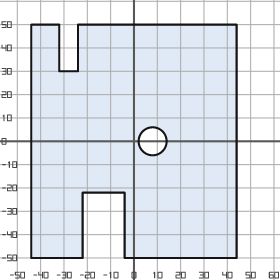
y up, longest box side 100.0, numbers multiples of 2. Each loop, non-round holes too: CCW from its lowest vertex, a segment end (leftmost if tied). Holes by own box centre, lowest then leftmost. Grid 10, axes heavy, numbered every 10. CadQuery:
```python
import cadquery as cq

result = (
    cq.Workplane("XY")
    .moveTo(-44.0, -50.0)
    .lineTo(-22.0, -50.0)
    .lineTo(-22.0, -22.0)
    .lineTo(-4.0, -22.0)
    .lineTo(-4.0, -50.0)
    .lineTo(44.0, -50.0)
    .lineTo(44.0, 50.0)
    .lineTo(-24.0, 50.0)
    .lineTo(-24.0, 30.0)
    .lineTo(-32.0, 30.0)
    .lineTo(-32.0, 50.0)
    .lineTo(-44.0, 50.0)
    .close()
    .moveTo(8.0, 0.0)
    .circle(6.0)
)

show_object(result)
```